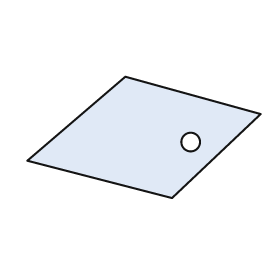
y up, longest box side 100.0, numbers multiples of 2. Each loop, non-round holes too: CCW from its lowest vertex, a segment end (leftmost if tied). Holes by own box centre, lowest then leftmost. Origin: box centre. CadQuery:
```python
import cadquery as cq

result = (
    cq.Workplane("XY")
    .moveTo(12.0, -26.0)
    .lineTo(50.0, 10.0)
    .lineTo(-8.0, 26.0)
    .lineTo(-50.0, -10.0)
    .close()
    .moveTo(20.0, -2.0)
    .circle(4.0)
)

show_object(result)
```